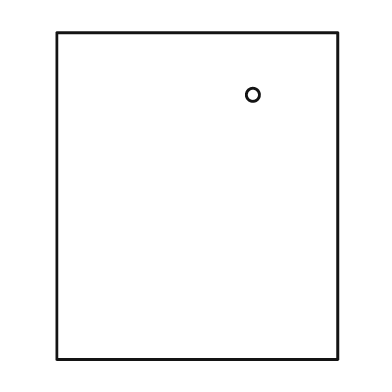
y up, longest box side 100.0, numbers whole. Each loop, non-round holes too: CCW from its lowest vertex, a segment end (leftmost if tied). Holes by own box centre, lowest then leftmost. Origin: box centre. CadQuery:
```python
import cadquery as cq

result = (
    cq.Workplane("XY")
    .moveTo(-43.0, -50.0)
    .lineTo(43.0, -50.0)
    .lineTo(43.0, 50.0)
    .lineTo(-43.0, 50.0)
    .close()
    .moveTo(17.0, 31.0)
    .circle(2.0)
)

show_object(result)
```